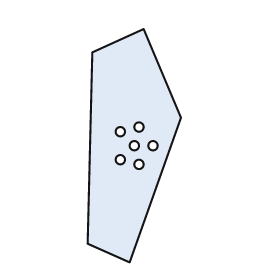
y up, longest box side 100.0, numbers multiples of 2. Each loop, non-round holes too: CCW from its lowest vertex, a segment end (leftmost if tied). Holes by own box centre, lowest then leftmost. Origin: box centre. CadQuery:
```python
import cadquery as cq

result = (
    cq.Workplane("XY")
    .moveTo(-2.0, -50.0)
    .lineTo(20.0, 12.0)
    .lineTo(4.0, 50.0)
    .lineTo(-18.0, 40.0)
    .lineTo(-20.0, -42.0)
    .close()
    .moveTo(2.0, -8.0)
    .circle(2.0)
    .moveTo(-6.0, -6.0)
    .circle(2.0)
    .moveTo(0.0, 0.0)
    .circle(2.0)
    .moveTo(8.0, 0.0)
    .circle(2.0)
    .moveTo(-6.0, 6.0)
    .circle(2.0)
    .moveTo(2.0, 8.0)
    .circle(2.0)
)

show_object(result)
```